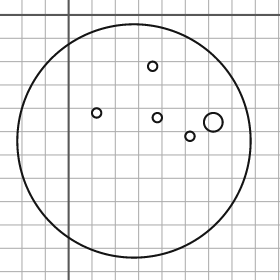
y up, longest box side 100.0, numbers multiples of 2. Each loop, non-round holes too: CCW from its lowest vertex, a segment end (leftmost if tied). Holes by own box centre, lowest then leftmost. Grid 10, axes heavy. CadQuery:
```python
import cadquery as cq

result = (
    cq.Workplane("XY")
    .moveTo(28.0, -54.0)
    .circle(50.0)
    .moveTo(52.0, -52.0)
    .circle(2.0)
    .moveTo(62.0, -46.0)
    .circle(4.0)
    .moveTo(38.0, -44.0)
    .circle(2.0)
    .moveTo(12.0, -42.0)
    .circle(2.0)
    .moveTo(36.0, -22.0)
    .circle(2.0)
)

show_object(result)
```